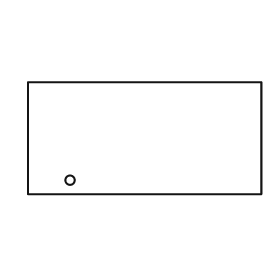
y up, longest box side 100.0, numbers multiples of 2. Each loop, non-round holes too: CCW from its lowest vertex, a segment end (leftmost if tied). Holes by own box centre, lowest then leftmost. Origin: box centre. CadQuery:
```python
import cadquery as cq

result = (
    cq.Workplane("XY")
    .moveTo(-50.0, -24.0)
    .lineTo(50.0, -24.0)
    .lineTo(50.0, 24.0)
    .lineTo(-50.0, 24.0)
    .close()
    .moveTo(-32.0, -18.0)
    .circle(2.0)
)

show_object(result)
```